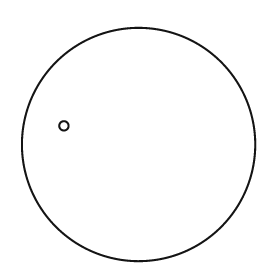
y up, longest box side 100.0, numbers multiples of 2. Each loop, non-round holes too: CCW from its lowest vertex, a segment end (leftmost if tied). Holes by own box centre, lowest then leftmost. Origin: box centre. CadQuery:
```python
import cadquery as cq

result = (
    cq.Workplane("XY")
    .moveTo(0.0, 0.0)
    .circle(50.0)
    .moveTo(-32.0, 8.0)
    .circle(2.0)
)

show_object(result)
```